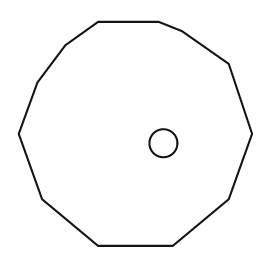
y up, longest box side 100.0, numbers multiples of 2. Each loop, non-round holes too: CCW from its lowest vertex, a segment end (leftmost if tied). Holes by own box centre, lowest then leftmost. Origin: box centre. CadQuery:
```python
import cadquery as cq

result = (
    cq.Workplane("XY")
    .moveTo(-16.0, -48.0)
    .lineTo(16.0, -48.0)
    .lineTo(40.0, -28.0)
    .lineTo(50.0, 0.0)
    .lineTo(40.0, 30.0)
    .lineTo(20.0, 44.0)
    .lineTo(10.0, 48.0)
    .lineTo(-16.0, 48.0)
    .lineTo(-30.0, 38.0)
    .lineTo(-42.0, 22.0)
    .lineTo(-50.0, 0.0)
    .lineTo(-40.0, -28.0)
    .close()
    .moveTo(12.0, -4.0)
    .circle(6.0)
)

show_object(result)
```